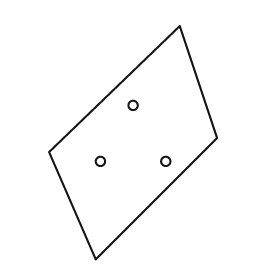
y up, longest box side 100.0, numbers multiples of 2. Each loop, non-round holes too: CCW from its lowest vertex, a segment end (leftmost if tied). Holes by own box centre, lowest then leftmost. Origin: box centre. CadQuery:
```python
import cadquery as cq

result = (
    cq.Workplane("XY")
    .moveTo(-16.0, -50.0)
    .lineTo(36.0, 2.0)
    .lineTo(20.0, 50.0)
    .lineTo(-36.0, -4.0)
    .close()
    .moveTo(-14.0, -8.0)
    .circle(2.0)
    .moveTo(14.0, -8.0)
    .circle(2.0)
    .moveTo(0.0, 16.0)
    .circle(2.0)
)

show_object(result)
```